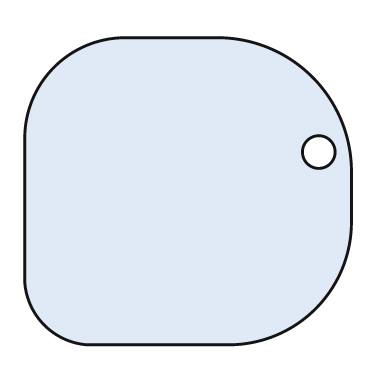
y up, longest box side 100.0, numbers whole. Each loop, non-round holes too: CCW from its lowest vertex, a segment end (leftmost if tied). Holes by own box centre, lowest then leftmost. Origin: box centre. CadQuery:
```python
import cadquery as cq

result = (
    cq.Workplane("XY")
    .moveTo(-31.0, -47.0)
    .lineTo(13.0, -47.0)
    .threePointArc((39.0, -36.0), (50.0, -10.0))
    .lineTo(50.0, 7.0)
    .threePointArc((38.0, 35.0), (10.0, 47.0))
    .lineTo(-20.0, 47.0)
    .threePointArc((-41.0, 38.0), (-50.0, 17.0))
    .lineTo(-50.0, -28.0)
    .threePointArc((-44.0, -41.0), (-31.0, -47.0))
    .close()
    .moveTo(40.0, 12.0)
    .circle(5.0)
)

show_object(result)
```